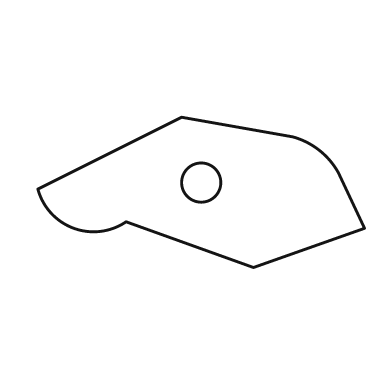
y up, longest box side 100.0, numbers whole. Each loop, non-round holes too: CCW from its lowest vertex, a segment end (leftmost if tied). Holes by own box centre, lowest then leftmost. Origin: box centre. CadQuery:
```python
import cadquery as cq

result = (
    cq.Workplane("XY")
    .moveTo(16.0, -23.0)
    .lineTo(50.0, -11.0)
    .lineTo(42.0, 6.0)
    .threePointArc((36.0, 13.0), (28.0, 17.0))
    .lineTo(-6.0, 23.0)
    .lineTo(-50.0, 1.0)
    .threePointArc((-39.0, -11.0), (-23.0, -9.0))
    .close()
    .moveTo(0.0, 3.0)
    .circle(6.0)
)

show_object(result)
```